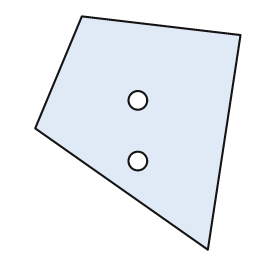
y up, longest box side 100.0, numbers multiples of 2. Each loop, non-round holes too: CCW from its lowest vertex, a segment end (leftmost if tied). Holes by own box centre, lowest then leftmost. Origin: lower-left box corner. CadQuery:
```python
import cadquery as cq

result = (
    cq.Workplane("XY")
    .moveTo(74.0, 0.0)
    .lineTo(88.0, 92.0)
    .lineTo(20.0, 100.0)
    .lineTo(0.0, 52.0)
    .close()
    .moveTo(44.0, 38.0)
    .circle(4.0)
    .moveTo(44.0, 64.0)
    .circle(4.0)
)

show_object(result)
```